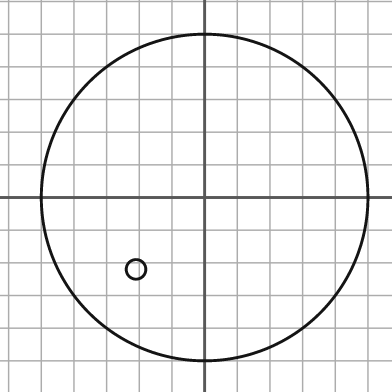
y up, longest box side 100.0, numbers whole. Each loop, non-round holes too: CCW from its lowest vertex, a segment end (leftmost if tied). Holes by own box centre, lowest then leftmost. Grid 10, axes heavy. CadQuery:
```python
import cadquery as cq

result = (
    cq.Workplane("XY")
    .moveTo(0.0, 0.0)
    .circle(50.0)
    .moveTo(-21.0, -22.0)
    .circle(3.0)
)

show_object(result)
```